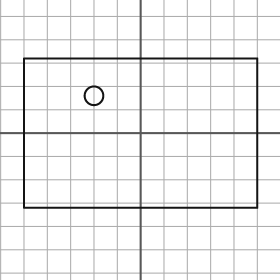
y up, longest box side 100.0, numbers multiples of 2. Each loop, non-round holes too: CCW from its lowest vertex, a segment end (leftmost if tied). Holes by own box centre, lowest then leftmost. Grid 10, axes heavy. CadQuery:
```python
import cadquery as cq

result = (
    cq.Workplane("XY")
    .moveTo(-50.0, -32.0)
    .lineTo(50.0, -32.0)
    .lineTo(50.0, 32.0)
    .lineTo(-50.0, 32.0)
    .close()
    .moveTo(-20.0, 16.0)
    .circle(4.0)
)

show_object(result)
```